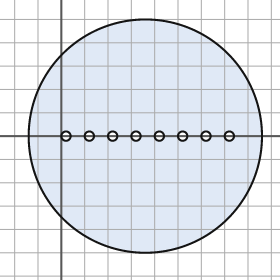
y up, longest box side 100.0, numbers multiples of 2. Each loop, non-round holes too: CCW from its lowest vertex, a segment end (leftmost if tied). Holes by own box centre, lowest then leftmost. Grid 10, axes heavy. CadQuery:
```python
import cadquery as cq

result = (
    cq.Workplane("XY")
    .moveTo(36.0, 0.0)
    .circle(50.0)
    .moveTo(2.0, 0.0)
    .circle(2.0)
    .moveTo(12.0, 0.0)
    .circle(2.0)
    .moveTo(22.0, 0.0)
    .circle(2.0)
    .moveTo(32.0, 0.0)
    .circle(2.0)
    .moveTo(42.0, 0.0)
    .circle(2.0)
    .moveTo(52.0, 0.0)
    .circle(2.0)
    .moveTo(62.0, 0.0)
    .circle(2.0)
    .moveTo(72.0, 0.0)
    .circle(2.0)
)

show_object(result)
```